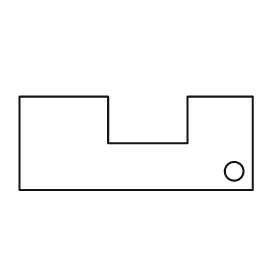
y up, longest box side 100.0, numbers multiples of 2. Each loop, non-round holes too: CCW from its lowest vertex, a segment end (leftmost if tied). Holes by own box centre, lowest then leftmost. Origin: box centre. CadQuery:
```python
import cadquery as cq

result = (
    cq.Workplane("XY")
    .moveTo(-50.0, -20.0)
    .lineTo(50.0, -20.0)
    .lineTo(50.0, 20.0)
    .lineTo(22.0, 20.0)
    .lineTo(22.0, 0.0)
    .lineTo(-12.0, 0.0)
    .lineTo(-12.0, 20.0)
    .lineTo(-50.0, 20.0)
    .close()
    .moveTo(42.0, -12.0)
    .circle(4.0)
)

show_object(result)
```